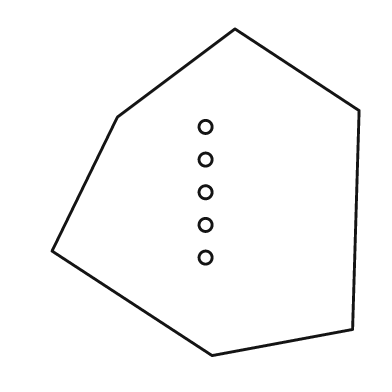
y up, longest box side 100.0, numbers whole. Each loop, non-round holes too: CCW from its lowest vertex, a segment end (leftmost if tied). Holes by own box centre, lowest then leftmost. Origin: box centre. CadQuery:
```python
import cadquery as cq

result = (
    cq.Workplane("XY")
    .moveTo(2.0, -50.0)
    .lineTo(45.0, -42.0)
    .lineTo(47.0, 25.0)
    .lineTo(9.0, 50.0)
    .lineTo(-27.0, 23.0)
    .lineTo(-47.0, -18.0)
    .close()
    .moveTo(0.0, -20.0)
    .circle(2.0)
    .moveTo(0.0, -10.0)
    .circle(2.0)
    .moveTo(0.0, 0.0)
    .circle(2.0)
    .moveTo(0.0, 10.0)
    .circle(2.0)
    .moveTo(0.0, 20.0)
    .circle(2.0)
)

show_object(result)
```